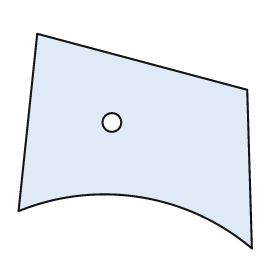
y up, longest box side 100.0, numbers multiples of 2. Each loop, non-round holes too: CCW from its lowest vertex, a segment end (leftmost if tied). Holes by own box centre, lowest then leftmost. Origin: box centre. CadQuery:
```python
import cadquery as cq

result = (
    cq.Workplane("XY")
    .moveTo(50.0, -46.0)
    .lineTo(48.0, 22.0)
    .lineTo(-42.0, 46.0)
    .lineTo(-50.0, -30.0)
    .threePointArc((2.0, -24.0), (50.0, -46.0))
    .close()
    .moveTo(-10.0, 8.0)
    .circle(4.0)
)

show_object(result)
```